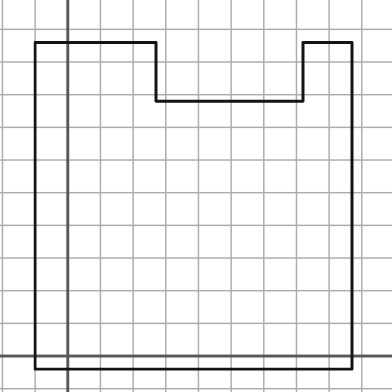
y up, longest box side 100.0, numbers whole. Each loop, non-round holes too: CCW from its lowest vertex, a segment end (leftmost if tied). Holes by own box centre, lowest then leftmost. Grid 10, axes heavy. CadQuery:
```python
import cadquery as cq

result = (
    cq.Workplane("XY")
    .moveTo(-10.0, -4.0)
    .lineTo(87.0, -4.0)
    .lineTo(87.0, 96.0)
    .lineTo(72.0, 96.0)
    .lineTo(72.0, 78.0)
    .lineTo(27.0, 78.0)
    .lineTo(27.0, 96.0)
    .lineTo(-10.0, 96.0)
    .close()
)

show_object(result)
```